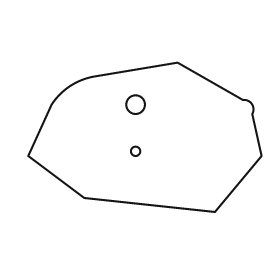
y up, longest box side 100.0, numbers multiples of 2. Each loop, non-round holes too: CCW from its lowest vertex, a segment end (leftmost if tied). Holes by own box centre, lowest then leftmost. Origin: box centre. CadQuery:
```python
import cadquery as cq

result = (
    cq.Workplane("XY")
    .moveTo(30.0, -32.0)
    .lineTo(50.0, -8.0)
    .lineTo(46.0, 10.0)
    .threePointArc((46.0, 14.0), (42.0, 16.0))
    .lineTo(14.0, 32.0)
    .lineTo(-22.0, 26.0)
    .threePointArc((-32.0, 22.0), (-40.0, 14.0))
    .lineTo(-50.0, -8.0)
    .lineTo(-26.0, -26.0)
    .close()
    .moveTo(-4.0, -6.0)
    .circle(2.0)
    .moveTo(-4.0, 14.0)
    .circle(4.0)
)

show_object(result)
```